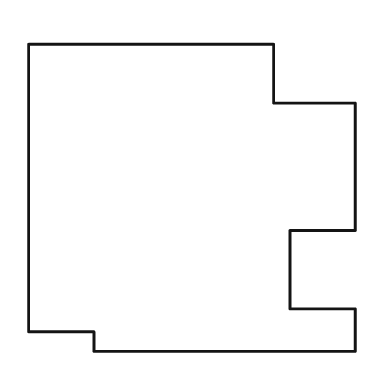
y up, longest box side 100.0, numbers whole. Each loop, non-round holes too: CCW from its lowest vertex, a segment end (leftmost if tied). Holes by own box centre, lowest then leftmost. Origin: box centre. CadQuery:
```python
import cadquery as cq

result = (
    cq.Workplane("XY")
    .moveTo(-30.0, -47.0)
    .lineTo(50.0, -47.0)
    .lineTo(50.0, -34.0)
    .lineTo(30.0, -34.0)
    .lineTo(30.0, -10.0)
    .lineTo(50.0, -10.0)
    .lineTo(50.0, 29.0)
    .lineTo(25.0, 29.0)
    .lineTo(25.0, 47.0)
    .lineTo(-50.0, 47.0)
    .lineTo(-50.0, -41.0)
    .lineTo(-30.0, -41.0)
    .close()
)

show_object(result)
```